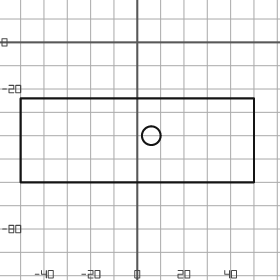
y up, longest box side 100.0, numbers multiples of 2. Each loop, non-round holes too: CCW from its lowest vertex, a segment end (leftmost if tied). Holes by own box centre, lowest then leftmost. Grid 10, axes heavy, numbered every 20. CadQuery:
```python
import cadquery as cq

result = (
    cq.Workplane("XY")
    .moveTo(-50.0, -60.0)
    .lineTo(50.0, -60.0)
    .lineTo(50.0, -24.0)
    .lineTo(-50.0, -24.0)
    .close()
    .moveTo(6.0, -40.0)
    .circle(4.0)
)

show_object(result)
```